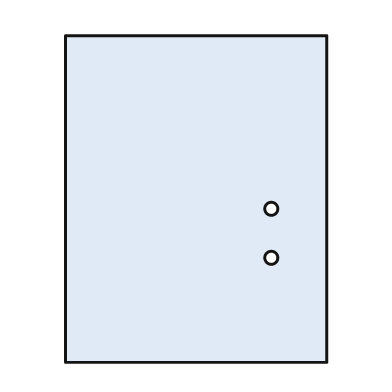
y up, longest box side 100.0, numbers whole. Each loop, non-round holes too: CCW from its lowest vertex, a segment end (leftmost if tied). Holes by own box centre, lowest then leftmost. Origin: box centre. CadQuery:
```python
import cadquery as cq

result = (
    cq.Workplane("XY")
    .moveTo(-40.0, -50.0)
    .lineTo(40.0, -50.0)
    .lineTo(40.0, 50.0)
    .lineTo(-40.0, 50.0)
    .close()
    .moveTo(23.0, -18.0)
    .circle(2.0)
    .moveTo(23.0, -3.0)
    .circle(2.0)
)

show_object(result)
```